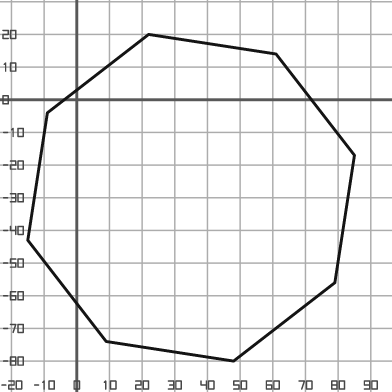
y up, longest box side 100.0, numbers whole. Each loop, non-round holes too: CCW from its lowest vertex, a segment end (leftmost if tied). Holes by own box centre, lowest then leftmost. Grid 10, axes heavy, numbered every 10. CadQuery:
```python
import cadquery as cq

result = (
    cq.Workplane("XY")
    .moveTo(48.0, -80.0)
    .lineTo(79.0, -56.0)
    .lineTo(85.0, -17.0)
    .lineTo(61.0, 14.0)
    .lineTo(22.0, 20.0)
    .lineTo(-9.0, -4.0)
    .lineTo(-15.0, -43.0)
    .lineTo(9.0, -74.0)
    .close()
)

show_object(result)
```